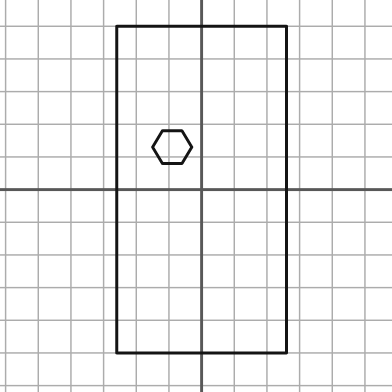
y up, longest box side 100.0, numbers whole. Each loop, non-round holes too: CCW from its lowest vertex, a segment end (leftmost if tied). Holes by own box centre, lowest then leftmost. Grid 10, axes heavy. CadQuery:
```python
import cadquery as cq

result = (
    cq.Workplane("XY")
    .moveTo(-26.0, -50.0)
    .lineTo(26.0, -50.0)
    .lineTo(26.0, 50.0)
    .lineTo(-26.0, 50.0)
    .close()
    .moveTo(-12.0, 8.0)
    .lineTo(-6.0, 8.0)
    .lineTo(-3.0, 13.0)
    .lineTo(-6.0, 18.0)
    .lineTo(-12.0, 18.0)
    .lineTo(-15.0, 13.0)
    .close()
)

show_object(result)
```